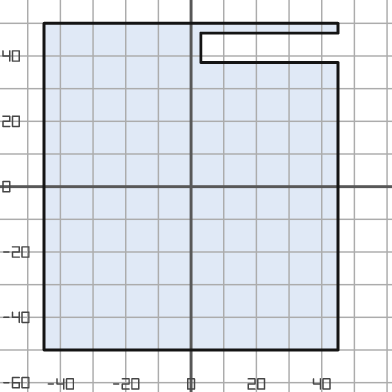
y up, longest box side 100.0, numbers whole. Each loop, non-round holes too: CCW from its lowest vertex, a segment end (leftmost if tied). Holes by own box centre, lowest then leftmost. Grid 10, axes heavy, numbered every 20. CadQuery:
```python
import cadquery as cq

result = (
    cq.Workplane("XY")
    .moveTo(-45.0, -50.0)
    .lineTo(45.0, -50.0)
    .lineTo(45.0, 38.0)
    .lineTo(3.0, 38.0)
    .lineTo(3.0, 47.0)
    .lineTo(45.0, 47.0)
    .lineTo(45.0, 50.0)
    .lineTo(-45.0, 50.0)
    .close()
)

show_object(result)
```